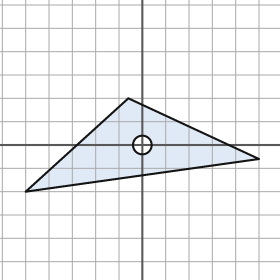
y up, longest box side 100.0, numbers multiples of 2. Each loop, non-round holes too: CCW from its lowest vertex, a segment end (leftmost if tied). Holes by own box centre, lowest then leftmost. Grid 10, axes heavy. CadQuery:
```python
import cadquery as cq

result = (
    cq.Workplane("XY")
    .moveTo(-50.0, -20.0)
    .lineTo(50.0, -6.0)
    .lineTo(-6.0, 20.0)
    .close()
    .moveTo(0.0, 0.0)
    .circle(4.0)
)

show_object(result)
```